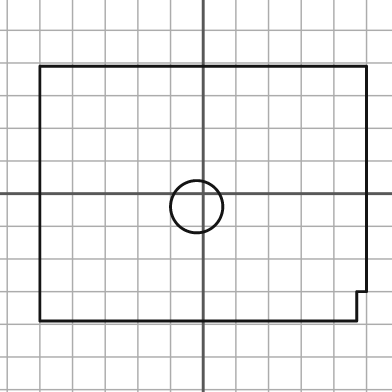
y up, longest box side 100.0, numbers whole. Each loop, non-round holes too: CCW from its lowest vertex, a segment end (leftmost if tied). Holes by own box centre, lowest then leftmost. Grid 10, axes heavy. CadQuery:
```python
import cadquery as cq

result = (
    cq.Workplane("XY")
    .moveTo(-50.0, -39.0)
    .lineTo(47.0, -39.0)
    .lineTo(47.0, -30.0)
    .lineTo(50.0, -30.0)
    .lineTo(50.0, 39.0)
    .lineTo(-50.0, 39.0)
    .close()
    .moveTo(-2.0, -4.0)
    .circle(8.0)
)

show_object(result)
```